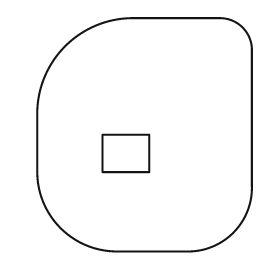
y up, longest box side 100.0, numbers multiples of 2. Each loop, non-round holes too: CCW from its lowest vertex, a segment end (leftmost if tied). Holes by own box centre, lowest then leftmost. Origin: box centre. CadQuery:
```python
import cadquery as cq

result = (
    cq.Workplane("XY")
    .moveTo(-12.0, -50.0)
    .lineTo(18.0, -50.0)
    .threePointArc((38.0, -42.0), (46.0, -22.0))
    .lineTo(46.0, 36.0)
    .threePointArc((42.0, 46.0), (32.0, 50.0))
    .lineTo(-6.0, 50.0)
    .threePointArc((-34.0, 38.0), (-46.0, 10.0))
    .lineTo(-46.0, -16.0)
    .threePointArc((-36.0, -40.0), (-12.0, -50.0))
    .close()
    .moveTo(-18.0, -16.0)
    .lineTo(2.0, -16.0)
    .lineTo(2.0, 0.0)
    .lineTo(-18.0, 0.0)
    .close()
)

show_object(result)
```